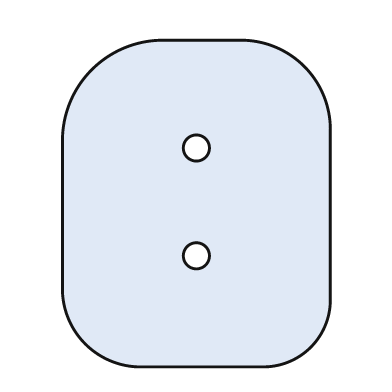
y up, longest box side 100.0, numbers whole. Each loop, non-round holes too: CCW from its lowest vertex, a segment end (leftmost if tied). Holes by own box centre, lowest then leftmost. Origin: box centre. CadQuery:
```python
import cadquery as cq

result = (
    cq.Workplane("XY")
    .moveTo(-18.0, -50.0)
    .lineTo(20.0, -50.0)
    .threePointArc((35.0, -44.0), (41.0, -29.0))
    .lineTo(41.0, 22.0)
    .threePointArc((33.0, 42.0), (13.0, 50.0))
    .lineTo(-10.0, 50.0)
    .threePointArc((-32.0, 41.0), (-41.0, 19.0))
    .lineTo(-41.0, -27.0)
    .threePointArc((-34.0, -43.0), (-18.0, -50.0))
    .close()
    .moveTo(0.0, -16.0)
    .circle(4.0)
    .moveTo(0.0, 17.0)
    .circle(4.0)
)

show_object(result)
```